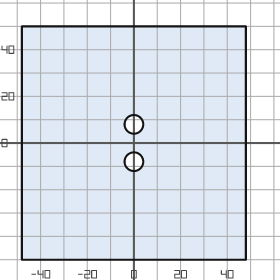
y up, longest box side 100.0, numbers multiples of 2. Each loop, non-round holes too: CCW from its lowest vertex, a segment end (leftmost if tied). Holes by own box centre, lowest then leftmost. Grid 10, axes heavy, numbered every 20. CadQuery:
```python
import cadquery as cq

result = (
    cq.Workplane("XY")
    .moveTo(-48.0, -50.0)
    .lineTo(48.0, -50.0)
    .lineTo(48.0, 50.0)
    .lineTo(-48.0, 50.0)
    .close()
    .moveTo(0.0, -8.0)
    .circle(4.0)
    .moveTo(0.0, 8.0)
    .circle(4.0)
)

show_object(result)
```